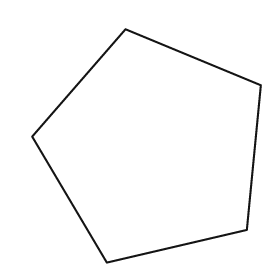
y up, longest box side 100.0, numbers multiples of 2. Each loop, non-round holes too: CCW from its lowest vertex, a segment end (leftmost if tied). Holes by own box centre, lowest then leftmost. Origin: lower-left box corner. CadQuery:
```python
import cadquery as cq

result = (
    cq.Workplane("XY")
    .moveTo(32.0, 0.0)
    .lineTo(92.0, 14.0)
    .lineTo(98.0, 76.0)
    .lineTo(40.0, 100.0)
    .lineTo(0.0, 54.0)
    .close()
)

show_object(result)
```